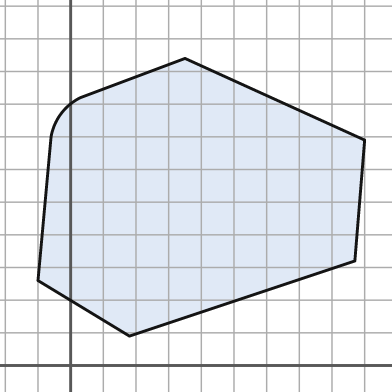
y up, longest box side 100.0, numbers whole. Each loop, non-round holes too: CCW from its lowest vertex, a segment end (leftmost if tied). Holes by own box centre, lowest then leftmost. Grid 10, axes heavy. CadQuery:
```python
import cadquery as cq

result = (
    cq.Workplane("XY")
    .moveTo(18.0, 9.0)
    .lineTo(87.0, 32.0)
    .lineTo(90.0, 69.0)
    .lineTo(35.0, 94.0)
    .lineTo(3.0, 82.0)
    .threePointArc((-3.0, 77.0), (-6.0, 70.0))
    .lineTo(-10.0, 26.0)
    .close()
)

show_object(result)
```